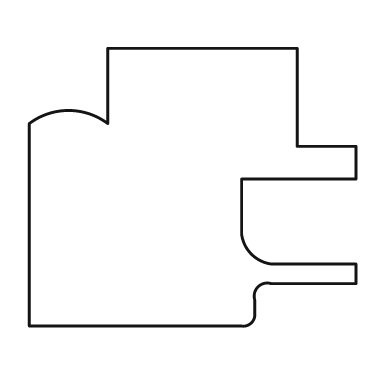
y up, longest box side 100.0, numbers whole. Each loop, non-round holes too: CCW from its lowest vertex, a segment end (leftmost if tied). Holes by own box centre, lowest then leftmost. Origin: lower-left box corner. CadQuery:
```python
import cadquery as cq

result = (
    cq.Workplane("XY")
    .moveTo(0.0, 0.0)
    .lineTo(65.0, 0.0)
    .threePointArc((68.0, 1.0), (69.0, 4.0))
    .lineTo(69.0, 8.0)
    .threePointArc((70.0, 12.0), (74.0, 13.0))
    .lineTo(100.0, 13.0)
    .lineTo(100.0, 19.0)
    .lineTo(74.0, 19.0)
    .threePointArc((68.0, 22.0), (65.0, 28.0))
    .lineTo(65.0, 45.0)
    .lineTo(100.0, 45.0)
    .lineTo(100.0, 55.0)
    .lineTo(82.0, 55.0)
    .lineTo(82.0, 85.0)
    .lineTo(24.0, 85.0)
    .lineTo(24.0, 62.0)
    .threePointArc((12.0, 66.0), (0.0, 62.0))
    .close()
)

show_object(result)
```